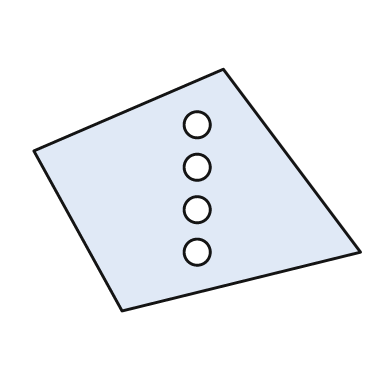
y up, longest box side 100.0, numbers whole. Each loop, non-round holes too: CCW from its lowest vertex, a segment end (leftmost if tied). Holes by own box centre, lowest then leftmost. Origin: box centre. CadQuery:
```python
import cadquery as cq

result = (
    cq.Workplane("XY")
    .moveTo(-23.0, -37.0)
    .lineTo(50.0, -19.0)
    .lineTo(8.0, 37.0)
    .lineTo(-50.0, 12.0)
    .close()
    .moveTo(0.0, -19.0)
    .circle(4.0)
    .moveTo(0.0, -6.0)
    .circle(4.0)
    .moveTo(0.0, 7.0)
    .circle(4.0)
    .moveTo(0.0, 20.0)
    .circle(4.0)
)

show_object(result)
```